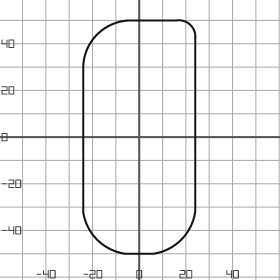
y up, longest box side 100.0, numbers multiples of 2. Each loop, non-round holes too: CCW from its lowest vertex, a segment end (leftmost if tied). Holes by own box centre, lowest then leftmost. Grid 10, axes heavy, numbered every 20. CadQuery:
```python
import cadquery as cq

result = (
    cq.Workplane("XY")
    .moveTo(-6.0, -50.0)
    .lineTo(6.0, -50.0)
    .threePointArc((18.0, -44.0), (24.0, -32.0))
    .lineTo(24.0, 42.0)
    .threePointArc((22.0, 48.0), (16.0, 50.0))
    .lineTo(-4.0, 50.0)
    .threePointArc((-18.0, 44.0), (-24.0, 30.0))
    .lineTo(-24.0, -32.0)
    .threePointArc((-18.0, -44.0), (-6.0, -50.0))
    .close()
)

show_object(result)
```